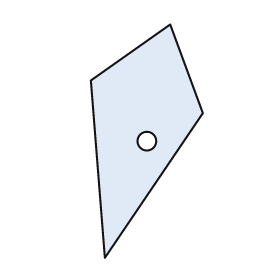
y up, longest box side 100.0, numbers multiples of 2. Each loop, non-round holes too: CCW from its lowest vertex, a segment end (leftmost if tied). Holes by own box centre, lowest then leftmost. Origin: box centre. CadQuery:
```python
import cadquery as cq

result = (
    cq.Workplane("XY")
    .moveTo(-18.0, -50.0)
    .lineTo(24.0, 12.0)
    .lineTo(10.0, 50.0)
    .lineTo(-24.0, 26.0)
    .close()
    .moveTo(0.0, 0.0)
    .circle(4.0)
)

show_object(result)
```